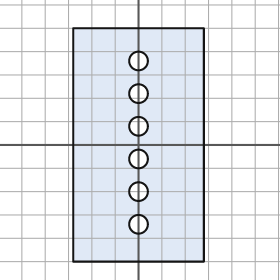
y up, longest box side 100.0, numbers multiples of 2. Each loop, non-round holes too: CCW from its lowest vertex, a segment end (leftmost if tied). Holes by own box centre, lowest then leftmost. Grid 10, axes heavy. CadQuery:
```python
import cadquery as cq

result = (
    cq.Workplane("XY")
    .moveTo(-28.0, -50.0)
    .lineTo(28.0, -50.0)
    .lineTo(28.0, 50.0)
    .lineTo(-28.0, 50.0)
    .close()
    .moveTo(0.0, -34.0)
    .circle(4.0)
    .moveTo(0.0, -20.0)
    .circle(4.0)
    .moveTo(0.0, -6.0)
    .circle(4.0)
    .moveTo(0.0, 8.0)
    .circle(4.0)
    .moveTo(0.0, 22.0)
    .circle(4.0)
    .moveTo(0.0, 36.0)
    .circle(4.0)
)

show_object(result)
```